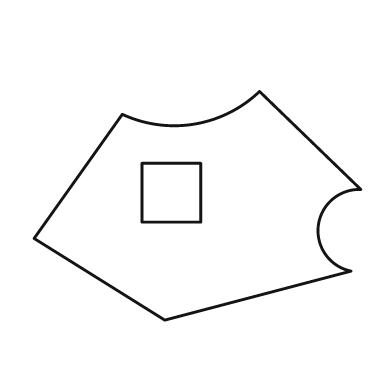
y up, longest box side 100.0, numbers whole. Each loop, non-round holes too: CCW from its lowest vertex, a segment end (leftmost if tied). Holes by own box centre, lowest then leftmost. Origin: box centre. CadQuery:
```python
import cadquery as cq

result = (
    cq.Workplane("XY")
    .moveTo(-10.0, -35.0)
    .lineTo(47.0, -20.0)
    .threePointArc((37.0, -6.0), (50.0, 5.0))
    .lineTo(19.0, 35.0)
    .threePointArc((-1.0, 25.0), (-23.0, 28.0))
    .lineTo(-50.0, -10.0)
    .close()
    .moveTo(-17.0, -5.0)
    .lineTo(1.0, -5.0)
    .lineTo(1.0, 13.0)
    .lineTo(-17.0, 13.0)
    .close()
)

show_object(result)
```